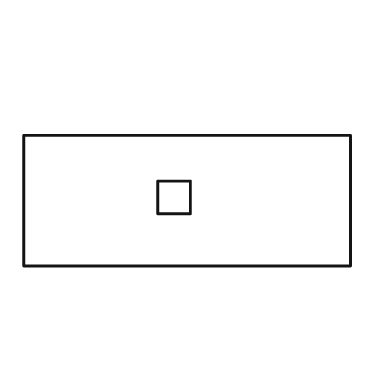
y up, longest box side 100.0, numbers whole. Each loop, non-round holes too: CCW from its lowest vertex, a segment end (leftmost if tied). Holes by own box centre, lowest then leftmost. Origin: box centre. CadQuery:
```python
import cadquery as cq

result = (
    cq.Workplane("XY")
    .moveTo(-50.0, -20.0)
    .lineTo(50.0, -20.0)
    .lineTo(50.0, 20.0)
    .lineTo(-50.0, 20.0)
    .close()
    .moveTo(-9.0, -4.0)
    .lineTo(1.0, -4.0)
    .lineTo(1.0, 6.0)
    .lineTo(-9.0, 6.0)
    .close()
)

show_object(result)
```